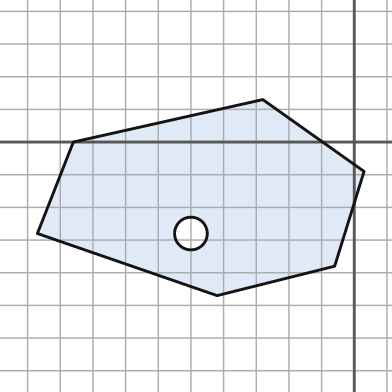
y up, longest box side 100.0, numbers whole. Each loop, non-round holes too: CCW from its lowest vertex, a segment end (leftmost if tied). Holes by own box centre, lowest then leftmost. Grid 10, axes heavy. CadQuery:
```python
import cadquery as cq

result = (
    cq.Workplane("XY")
    .moveTo(-42.0, -47.0)
    .lineTo(-6.0, -38.0)
    .lineTo(3.0, -9.0)
    .lineTo(-28.0, 13.0)
    .lineTo(-86.0, 0.0)
    .lineTo(-97.0, -28.0)
    .close()
    .moveTo(-50.0, -28.0)
    .circle(5.0)
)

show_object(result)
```